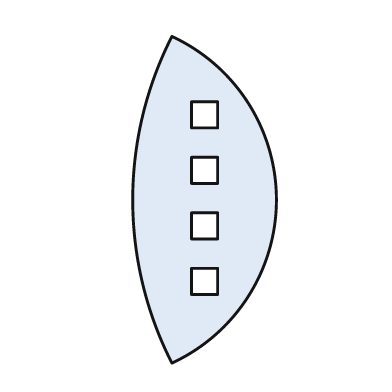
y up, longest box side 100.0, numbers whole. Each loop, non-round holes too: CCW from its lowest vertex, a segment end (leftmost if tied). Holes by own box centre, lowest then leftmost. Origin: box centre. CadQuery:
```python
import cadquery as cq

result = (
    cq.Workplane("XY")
    .moveTo(-10.0, -50.0)
    .threePointArc((22.0, 0.0), (-10.0, 50.0))
    .threePointArc((-22.0, 0.0), (-10.0, -50.0))
    .close()
    .moveTo(-4.0, -29.0)
    .lineTo(4.0, -29.0)
    .lineTo(4.0, -21.0)
    .lineTo(-4.0, -21.0)
    .close()
    .moveTo(-4.0, -12.0)
    .lineTo(4.0, -12.0)
    .lineTo(4.0, -4.0)
    .lineTo(-4.0, -4.0)
    .close()
    .moveTo(-4.0, 5.0)
    .lineTo(4.0, 5.0)
    .lineTo(4.0, 13.0)
    .lineTo(-4.0, 13.0)
    .close()
    .moveTo(-4.0, 22.0)
    .lineTo(4.0, 22.0)
    .lineTo(4.0, 30.0)
    .lineTo(-4.0, 30.0)
    .close()
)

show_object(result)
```